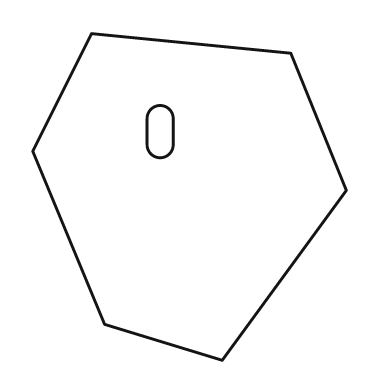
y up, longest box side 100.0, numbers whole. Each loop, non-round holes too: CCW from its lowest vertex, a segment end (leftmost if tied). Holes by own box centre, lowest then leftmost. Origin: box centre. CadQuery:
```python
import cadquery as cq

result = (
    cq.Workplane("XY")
    .moveTo(10.0, -50.0)
    .lineTo(48.0, 2.0)
    .lineTo(31.0, 44.0)
    .lineTo(-30.0, 50.0)
    .lineTo(-48.0, 14.0)
    .lineTo(-26.0, -39.0)
    .close()
    .moveTo(-13.0, 16.0)
    .threePointArc((-9.0, 12.0), (-5.0, 16.0))
    .lineTo(-5.0, 24.0)
    .threePointArc((-9.0, 28.0), (-13.0, 24.0))
    .close()
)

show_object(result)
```